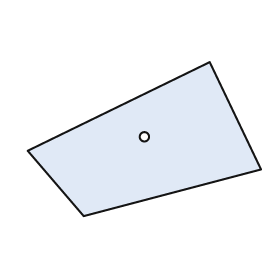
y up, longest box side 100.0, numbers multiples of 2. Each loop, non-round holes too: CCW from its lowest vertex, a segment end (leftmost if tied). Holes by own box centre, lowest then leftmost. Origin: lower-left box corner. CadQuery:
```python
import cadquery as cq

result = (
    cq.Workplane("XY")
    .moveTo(24.0, 0.0)
    .lineTo(100.0, 20.0)
    .lineTo(78.0, 66.0)
    .lineTo(0.0, 28.0)
    .close()
    .moveTo(50.0, 34.0)
    .circle(2.0)
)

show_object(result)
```